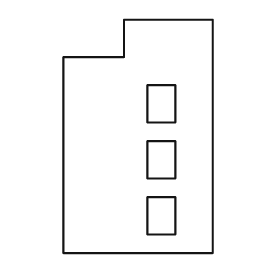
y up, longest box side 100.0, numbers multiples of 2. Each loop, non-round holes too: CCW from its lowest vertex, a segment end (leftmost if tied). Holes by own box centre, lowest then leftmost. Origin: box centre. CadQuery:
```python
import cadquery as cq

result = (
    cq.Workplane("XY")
    .moveTo(-32.0, -50.0)
    .lineTo(32.0, -50.0)
    .lineTo(32.0, 50.0)
    .lineTo(-6.0, 50.0)
    .lineTo(-6.0, 34.0)
    .lineTo(-32.0, 34.0)
    .close()
    .moveTo(4.0, -42.0)
    .lineTo(16.0, -42.0)
    .lineTo(16.0, -26.0)
    .lineTo(4.0, -26.0)
    .close()
    .moveTo(4.0, -18.0)
    .lineTo(16.0, -18.0)
    .lineTo(16.0, -2.0)
    .lineTo(4.0, -2.0)
    .close()
    .moveTo(4.0, 6.0)
    .lineTo(16.0, 6.0)
    .lineTo(16.0, 22.0)
    .lineTo(4.0, 22.0)
    .close()
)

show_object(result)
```